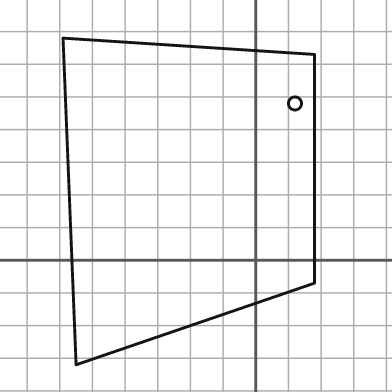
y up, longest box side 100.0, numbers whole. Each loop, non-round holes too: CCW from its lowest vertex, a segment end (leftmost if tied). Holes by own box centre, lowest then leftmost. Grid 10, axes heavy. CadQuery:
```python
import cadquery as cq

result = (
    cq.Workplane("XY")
    .moveTo(-55.0, -32.0)
    .lineTo(18.0, -7.0)
    .lineTo(18.0, 63.0)
    .lineTo(-59.0, 68.0)
    .close()
    .moveTo(12.0, 48.0)
    .circle(2.0)
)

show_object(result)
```